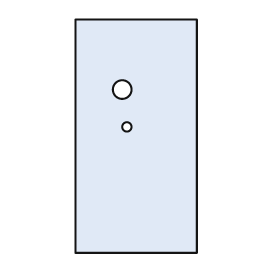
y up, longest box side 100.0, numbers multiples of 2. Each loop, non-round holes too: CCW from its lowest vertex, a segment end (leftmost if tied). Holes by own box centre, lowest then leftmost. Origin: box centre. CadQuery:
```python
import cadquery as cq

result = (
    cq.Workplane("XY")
    .moveTo(-26.0, -50.0)
    .lineTo(26.0, -50.0)
    .lineTo(26.0, 50.0)
    .lineTo(-26.0, 50.0)
    .close()
    .moveTo(-4.0, 4.0)
    .circle(2.0)
    .moveTo(-6.0, 20.0)
    .circle(4.0)
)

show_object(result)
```